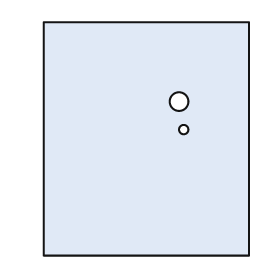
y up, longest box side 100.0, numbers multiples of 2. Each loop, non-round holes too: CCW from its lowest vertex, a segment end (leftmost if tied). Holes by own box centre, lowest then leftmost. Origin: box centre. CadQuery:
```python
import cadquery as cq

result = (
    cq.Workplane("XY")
    .moveTo(-44.0, -50.0)
    .lineTo(44.0, -50.0)
    .lineTo(44.0, 50.0)
    .lineTo(-44.0, 50.0)
    .close()
    .moveTo(16.0, 4.0)
    .circle(2.0)
    .moveTo(14.0, 16.0)
    .circle(4.0)
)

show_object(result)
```